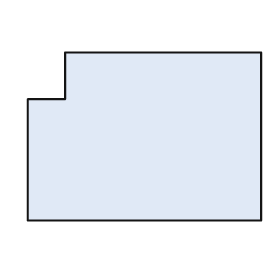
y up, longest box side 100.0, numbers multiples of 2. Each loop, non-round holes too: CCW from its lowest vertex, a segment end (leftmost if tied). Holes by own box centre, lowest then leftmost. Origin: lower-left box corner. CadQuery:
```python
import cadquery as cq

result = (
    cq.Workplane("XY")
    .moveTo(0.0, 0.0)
    .lineTo(100.0, 0.0)
    .lineTo(100.0, 72.0)
    .lineTo(16.0, 72.0)
    .lineTo(16.0, 52.0)
    .lineTo(0.0, 52.0)
    .close()
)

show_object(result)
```